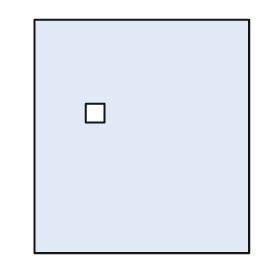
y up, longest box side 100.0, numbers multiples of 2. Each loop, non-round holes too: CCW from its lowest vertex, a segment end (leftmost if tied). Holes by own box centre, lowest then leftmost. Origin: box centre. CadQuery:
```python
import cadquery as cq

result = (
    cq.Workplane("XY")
    .moveTo(-46.0, -50.0)
    .lineTo(46.0, -50.0)
    .lineTo(46.0, 50.0)
    .lineTo(-46.0, 50.0)
    .close()
    .moveTo(-24.0, 6.0)
    .lineTo(-16.0, 6.0)
    .lineTo(-16.0, 14.0)
    .lineTo(-24.0, 14.0)
    .close()
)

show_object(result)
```